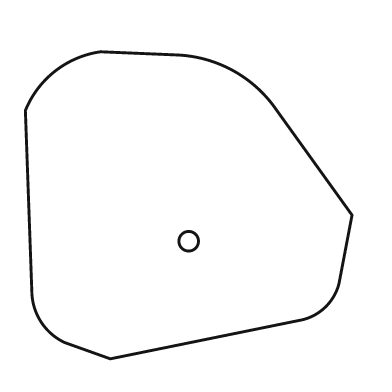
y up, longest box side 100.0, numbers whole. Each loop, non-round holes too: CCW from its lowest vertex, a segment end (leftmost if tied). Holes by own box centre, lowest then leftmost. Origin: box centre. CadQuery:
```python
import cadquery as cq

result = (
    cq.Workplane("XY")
    .moveTo(-24.0, -47.0)
    .lineTo(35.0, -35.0)
    .threePointArc((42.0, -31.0), (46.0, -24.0))
    .lineTo(50.0, -3.0)
    .lineTo(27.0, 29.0)
    .threePointArc((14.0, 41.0), (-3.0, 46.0))
    .lineTo(-27.0, 47.0)
    .threePointArc((-41.0, 41.0), (-50.0, 29.0))
    .lineTo(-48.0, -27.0)
    .threePointArc((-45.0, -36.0), (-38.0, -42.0))
    .close()
    .moveTo(0.0, -11.0)
    .circle(3.0)
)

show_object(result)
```